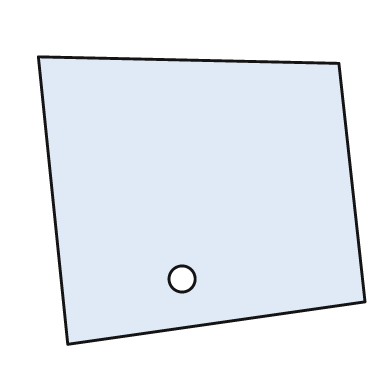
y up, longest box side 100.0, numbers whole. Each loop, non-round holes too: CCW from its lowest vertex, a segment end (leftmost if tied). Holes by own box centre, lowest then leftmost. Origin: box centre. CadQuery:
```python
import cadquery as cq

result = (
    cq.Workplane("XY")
    .moveTo(-41.0, -44.0)
    .lineTo(50.0, -31.0)
    .lineTo(42.0, 42.0)
    .lineTo(-50.0, 44.0)
    .close()
    .moveTo(-6.0, -24.0)
    .circle(4.0)
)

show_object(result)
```